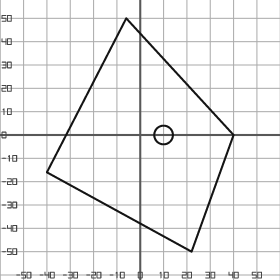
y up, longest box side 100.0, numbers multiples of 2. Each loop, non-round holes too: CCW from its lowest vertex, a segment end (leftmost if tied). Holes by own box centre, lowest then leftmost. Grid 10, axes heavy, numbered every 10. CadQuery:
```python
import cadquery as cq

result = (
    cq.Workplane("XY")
    .moveTo(22.0, -50.0)
    .lineTo(40.0, 0.0)
    .lineTo(-6.0, 50.0)
    .lineTo(-40.0, -16.0)
    .close()
    .moveTo(10.0, 0.0)
    .circle(4.0)
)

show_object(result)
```